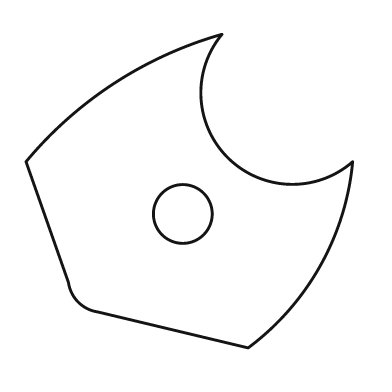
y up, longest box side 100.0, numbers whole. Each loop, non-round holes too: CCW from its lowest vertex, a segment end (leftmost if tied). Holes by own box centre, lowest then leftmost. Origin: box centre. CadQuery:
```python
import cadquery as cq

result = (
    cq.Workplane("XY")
    .moveTo(18.0, -48.0)
    .threePointArc((40.0, -23.0), (50.0, 9.0))
    .threePointArc((12.0, 10.0), (10.0, 48.0))
    .threePointArc((-23.0, 33.0), (-50.0, 9.0))
    .lineTo(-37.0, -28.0)
    .threePointArc((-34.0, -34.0), (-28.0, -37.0))
    .close()
    .moveTo(-2.0, -7.0)
    .circle(9.0)
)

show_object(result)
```